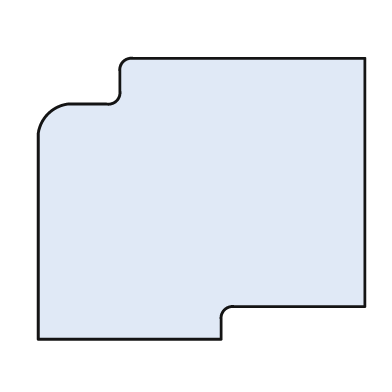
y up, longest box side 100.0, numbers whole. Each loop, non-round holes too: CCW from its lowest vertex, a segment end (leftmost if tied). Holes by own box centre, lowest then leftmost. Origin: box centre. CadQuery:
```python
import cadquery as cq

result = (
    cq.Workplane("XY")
    .moveTo(-50.0, -43.0)
    .lineTo(6.0, -43.0)
    .lineTo(6.0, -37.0)
    .threePointArc((7.0, -34.0), (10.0, -33.0))
    .lineTo(50.0, -33.0)
    .lineTo(50.0, 43.0)
    .lineTo(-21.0, 43.0)
    .threePointArc((-24.0, 42.0), (-25.0, 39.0))
    .lineTo(-25.0, 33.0)
    .threePointArc((-26.0, 30.0), (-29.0, 29.0))
    .lineTo(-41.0, 29.0)
    .threePointArc((-47.0, 26.0), (-50.0, 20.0))
    .close()
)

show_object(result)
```